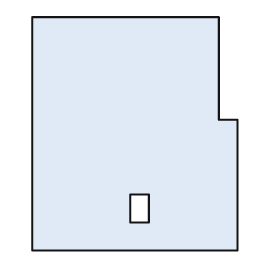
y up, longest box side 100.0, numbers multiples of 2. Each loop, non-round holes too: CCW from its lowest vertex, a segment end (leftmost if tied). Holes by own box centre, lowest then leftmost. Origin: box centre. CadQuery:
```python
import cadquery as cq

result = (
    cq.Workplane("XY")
    .moveTo(-44.0, -50.0)
    .lineTo(44.0, -50.0)
    .lineTo(44.0, 6.0)
    .lineTo(36.0, 6.0)
    .lineTo(36.0, 50.0)
    .lineTo(-44.0, 50.0)
    .close()
    .moveTo(-2.0, -38.0)
    .lineTo(6.0, -38.0)
    .lineTo(6.0, -26.0)
    .lineTo(-2.0, -26.0)
    .close()
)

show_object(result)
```